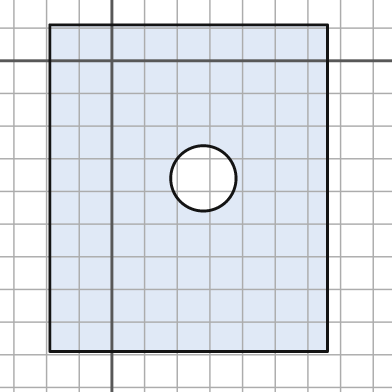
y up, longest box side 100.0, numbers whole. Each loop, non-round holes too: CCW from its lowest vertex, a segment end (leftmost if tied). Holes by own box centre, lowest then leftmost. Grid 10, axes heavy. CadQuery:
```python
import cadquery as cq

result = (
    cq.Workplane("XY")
    .moveTo(-19.0, -89.0)
    .lineTo(66.0, -89.0)
    .lineTo(66.0, 11.0)
    .lineTo(-19.0, 11.0)
    .close()
    .moveTo(28.0, -36.0)
    .circle(10.0)
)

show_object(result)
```